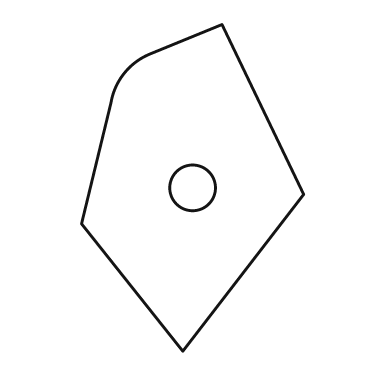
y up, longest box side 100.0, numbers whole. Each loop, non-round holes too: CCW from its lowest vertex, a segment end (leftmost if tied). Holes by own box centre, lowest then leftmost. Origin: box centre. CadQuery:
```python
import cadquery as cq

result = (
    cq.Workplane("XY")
    .moveTo(-3.0, -50.0)
    .lineTo(34.0, -2.0)
    .lineTo(9.0, 50.0)
    .lineTo(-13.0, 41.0)
    .threePointArc((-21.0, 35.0), (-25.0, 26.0))
    .lineTo(-34.0, -11.0)
    .close()
    .moveTo(0.0, 0.0)
    .circle(7.0)
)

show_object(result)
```